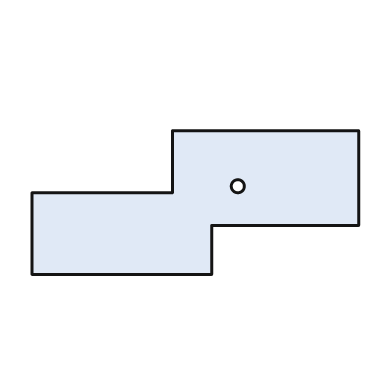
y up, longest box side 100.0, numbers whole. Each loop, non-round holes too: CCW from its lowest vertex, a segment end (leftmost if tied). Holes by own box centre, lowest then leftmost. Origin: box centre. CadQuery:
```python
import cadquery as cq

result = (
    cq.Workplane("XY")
    .moveTo(-50.0, -22.0)
    .lineTo(5.0, -22.0)
    .lineTo(5.0, -7.0)
    .lineTo(50.0, -7.0)
    .lineTo(50.0, 22.0)
    .lineTo(-7.0, 22.0)
    .lineTo(-7.0, 3.0)
    .lineTo(-50.0, 3.0)
    .close()
    .moveTo(13.0, 5.0)
    .circle(2.0)
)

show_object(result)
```